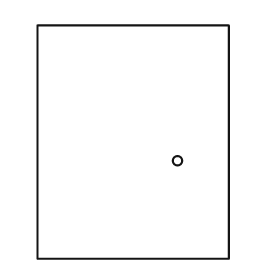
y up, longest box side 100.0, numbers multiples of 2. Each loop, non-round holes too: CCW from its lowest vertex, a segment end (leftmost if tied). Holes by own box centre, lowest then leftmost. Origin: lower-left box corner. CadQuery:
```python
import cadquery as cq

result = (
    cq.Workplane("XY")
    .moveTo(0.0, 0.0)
    .lineTo(82.0, 0.0)
    .lineTo(82.0, 100.0)
    .lineTo(0.0, 100.0)
    .close()
    .moveTo(60.0, 42.0)
    .circle(2.0)
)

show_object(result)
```